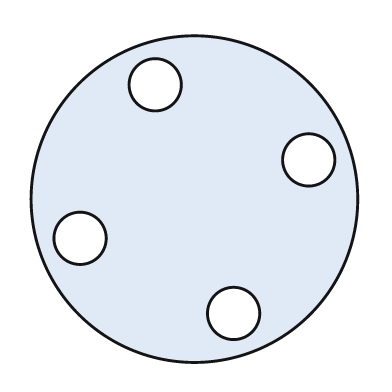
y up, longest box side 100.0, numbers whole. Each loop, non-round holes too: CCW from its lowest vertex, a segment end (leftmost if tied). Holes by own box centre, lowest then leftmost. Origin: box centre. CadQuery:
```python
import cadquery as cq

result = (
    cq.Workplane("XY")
    .moveTo(0.0, 0.0)
    .circle(50.0)
    .moveTo(12.0, -35.0)
    .circle(8.0)
    .moveTo(-35.0, -12.0)
    .circle(8.0)
    .moveTo(35.0, 12.0)
    .circle(8.0)
    .moveTo(-12.0, 35.0)
    .circle(8.0)
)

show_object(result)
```